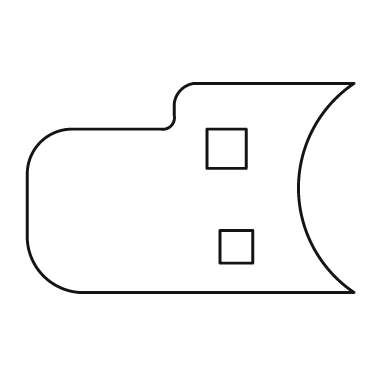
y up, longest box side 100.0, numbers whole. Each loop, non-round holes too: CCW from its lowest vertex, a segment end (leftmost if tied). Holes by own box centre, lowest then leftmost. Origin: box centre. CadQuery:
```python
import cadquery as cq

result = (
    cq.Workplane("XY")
    .moveTo(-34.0, -32.0)
    .lineTo(50.0, -32.0)
    .threePointArc((33.0, 0.0), (50.0, 32.0))
    .lineTo(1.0, 32.0)
    .threePointArc((-3.0, 30.0), (-5.0, 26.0))
    .lineTo(-5.0, 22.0)
    .threePointArc((-6.0, 19.0), (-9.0, 18.0))
    .lineTo(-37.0, 18.0)
    .threePointArc((-46.0, 14.0), (-50.0, 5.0))
    .lineTo(-50.0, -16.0)
    .threePointArc((-45.0, -27.0), (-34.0, -32.0))
    .close()
    .moveTo(9.0, -23.0)
    .lineTo(19.0, -23.0)
    .lineTo(19.0, -13.0)
    .lineTo(9.0, -13.0)
    .close()
    .moveTo(5.0, 6.0)
    .lineTo(17.0, 6.0)
    .lineTo(17.0, 18.0)
    .lineTo(5.0, 18.0)
    .close()
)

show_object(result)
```